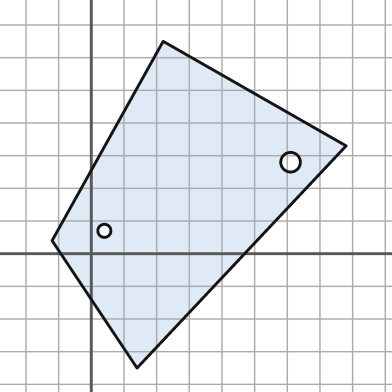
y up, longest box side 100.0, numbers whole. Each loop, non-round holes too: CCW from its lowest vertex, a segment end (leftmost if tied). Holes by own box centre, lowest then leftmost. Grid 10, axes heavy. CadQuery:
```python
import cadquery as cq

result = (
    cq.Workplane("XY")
    .moveTo(14.0, -35.0)
    .lineTo(78.0, 33.0)
    .lineTo(22.0, 65.0)
    .lineTo(-12.0, 4.0)
    .close()
    .moveTo(4.0, 7.0)
    .circle(2.0)
    .moveTo(61.0, 28.0)
    .circle(3.0)
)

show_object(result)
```